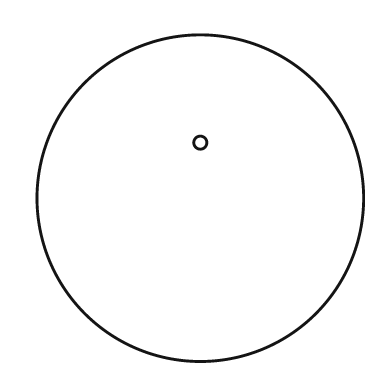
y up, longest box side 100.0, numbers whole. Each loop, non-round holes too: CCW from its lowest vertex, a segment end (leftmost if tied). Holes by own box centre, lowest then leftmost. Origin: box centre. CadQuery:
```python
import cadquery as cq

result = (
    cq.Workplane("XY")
    .moveTo(0.0, 0.0)
    .circle(50.0)
    .moveTo(0.0, 17.0)
    .circle(2.0)
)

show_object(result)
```